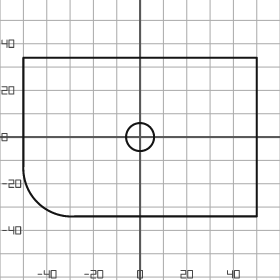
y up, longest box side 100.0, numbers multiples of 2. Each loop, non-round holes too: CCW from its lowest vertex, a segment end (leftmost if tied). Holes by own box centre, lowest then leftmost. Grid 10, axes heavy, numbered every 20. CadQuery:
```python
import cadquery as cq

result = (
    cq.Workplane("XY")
    .moveTo(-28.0, -34.0)
    .lineTo(50.0, -34.0)
    .lineTo(50.0, 34.0)
    .lineTo(-50.0, 34.0)
    .lineTo(-50.0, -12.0)
    .threePointArc((-44.0, -28.0), (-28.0, -34.0))
    .close()
    .moveTo(0.0, 0.0)
    .circle(6.0)
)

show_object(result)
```